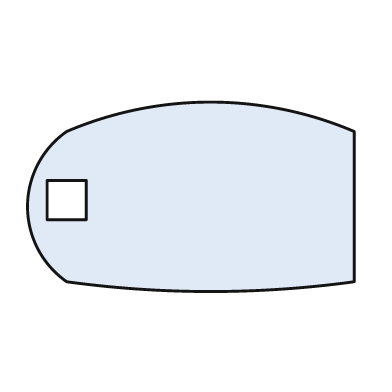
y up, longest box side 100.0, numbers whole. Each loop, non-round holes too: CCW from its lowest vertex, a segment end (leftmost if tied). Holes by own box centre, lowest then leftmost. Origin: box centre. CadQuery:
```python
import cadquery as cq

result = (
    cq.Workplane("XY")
    .moveTo(-38.0, -26.0)
    .threePointArc((6.0, -29.0), (50.0, -26.0))
    .lineTo(50.0, 20.0)
    .threePointArc((6.0, 29.0), (-38.0, 20.0))
    .threePointArc((-50.0, -3.0), (-38.0, -26.0))
    .close()
    .moveTo(-44.0, -7.0)
    .lineTo(-32.0, -7.0)
    .lineTo(-32.0, 5.0)
    .lineTo(-44.0, 5.0)
    .close()
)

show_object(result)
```